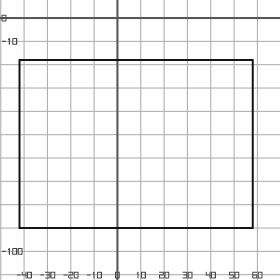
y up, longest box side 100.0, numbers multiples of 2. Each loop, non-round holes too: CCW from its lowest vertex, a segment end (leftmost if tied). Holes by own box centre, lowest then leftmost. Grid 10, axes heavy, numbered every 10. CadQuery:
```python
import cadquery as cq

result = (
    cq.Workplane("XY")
    .moveTo(-42.0, -90.0)
    .lineTo(58.0, -90.0)
    .lineTo(58.0, -18.0)
    .lineTo(-42.0, -18.0)
    .close()
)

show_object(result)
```